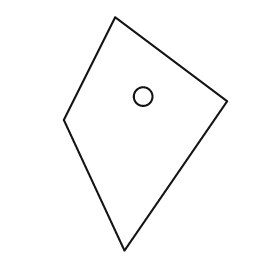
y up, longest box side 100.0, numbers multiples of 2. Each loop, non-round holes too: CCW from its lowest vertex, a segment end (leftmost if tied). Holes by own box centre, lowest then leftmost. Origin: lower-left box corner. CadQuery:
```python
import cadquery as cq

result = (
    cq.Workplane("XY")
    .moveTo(26.0, 0.0)
    .lineTo(70.0, 64.0)
    .lineTo(22.0, 100.0)
    .lineTo(0.0, 56.0)
    .close()
    .moveTo(34.0, 66.0)
    .circle(4.0)
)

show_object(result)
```